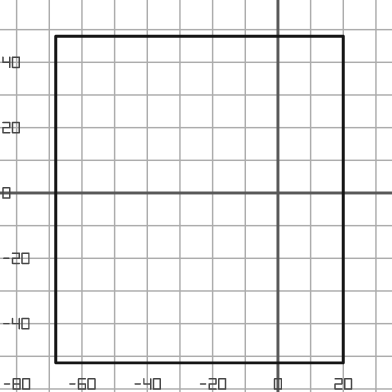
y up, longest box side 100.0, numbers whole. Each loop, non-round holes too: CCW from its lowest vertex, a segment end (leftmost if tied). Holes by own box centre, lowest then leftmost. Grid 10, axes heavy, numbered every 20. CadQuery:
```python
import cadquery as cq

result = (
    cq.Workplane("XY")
    .moveTo(-68.0, -52.0)
    .lineTo(20.0, -52.0)
    .lineTo(20.0, 48.0)
    .lineTo(-68.0, 48.0)
    .close()
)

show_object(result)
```